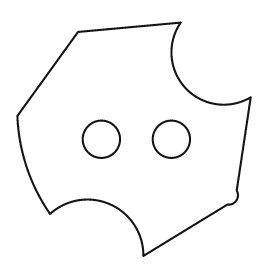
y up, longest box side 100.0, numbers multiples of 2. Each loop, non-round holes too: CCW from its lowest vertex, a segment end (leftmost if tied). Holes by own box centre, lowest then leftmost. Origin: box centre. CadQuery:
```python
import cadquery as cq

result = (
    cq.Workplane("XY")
    .moveTo(4.0, -50.0)
    .lineTo(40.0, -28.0)
    .threePointArc((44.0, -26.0), (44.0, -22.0))
    .lineTo(50.0, 18.0)
    .threePointArc((22.0, 22.0), (20.0, 50.0))
    .lineTo(-24.0, 46.0)
    .lineTo(-50.0, 10.0)
    .threePointArc((-46.0, -12.0), (-36.0, -32.0))
    .threePointArc((-10.0, -28.0), (4.0, -50.0))
    .close()
    .moveTo(-14.0, 0.0)
    .circle(8.0)
    .moveTo(16.0, 0.0)
    .circle(8.0)
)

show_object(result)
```